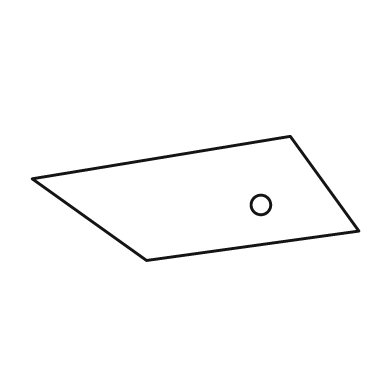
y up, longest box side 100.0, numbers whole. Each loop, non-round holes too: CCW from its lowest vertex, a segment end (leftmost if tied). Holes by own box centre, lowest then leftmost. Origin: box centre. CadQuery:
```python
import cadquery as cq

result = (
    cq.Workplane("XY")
    .moveTo(-15.0, -19.0)
    .lineTo(50.0, -10.0)
    .lineTo(29.0, 19.0)
    .lineTo(-50.0, 6.0)
    .close()
    .moveTo(20.0, -2.0)
    .circle(3.0)
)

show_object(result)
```